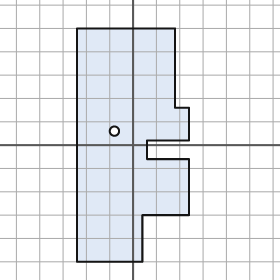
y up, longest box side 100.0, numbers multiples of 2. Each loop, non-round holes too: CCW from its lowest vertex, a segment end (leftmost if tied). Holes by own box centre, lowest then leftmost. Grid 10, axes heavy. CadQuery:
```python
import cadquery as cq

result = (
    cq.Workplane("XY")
    .moveTo(-24.0, -50.0)
    .lineTo(4.0, -50.0)
    .lineTo(4.0, -30.0)
    .lineTo(24.0, -30.0)
    .lineTo(24.0, -6.0)
    .lineTo(6.0, -6.0)
    .lineTo(6.0, 2.0)
    .lineTo(24.0, 2.0)
    .lineTo(24.0, 16.0)
    .lineTo(18.0, 16.0)
    .lineTo(18.0, 50.0)
    .lineTo(-24.0, 50.0)
    .close()
    .moveTo(-8.0, 6.0)
    .circle(2.0)
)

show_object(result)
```